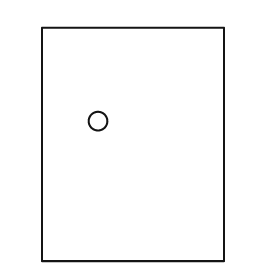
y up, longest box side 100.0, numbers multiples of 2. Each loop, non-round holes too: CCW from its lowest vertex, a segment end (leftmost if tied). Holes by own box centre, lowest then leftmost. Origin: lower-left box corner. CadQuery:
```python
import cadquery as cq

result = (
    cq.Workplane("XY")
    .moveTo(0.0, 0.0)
    .lineTo(78.0, 0.0)
    .lineTo(78.0, 100.0)
    .lineTo(0.0, 100.0)
    .close()
    .moveTo(24.0, 60.0)
    .circle(4.0)
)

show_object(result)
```